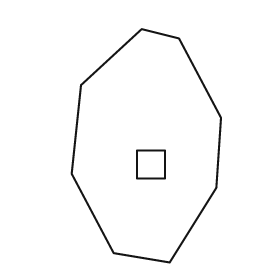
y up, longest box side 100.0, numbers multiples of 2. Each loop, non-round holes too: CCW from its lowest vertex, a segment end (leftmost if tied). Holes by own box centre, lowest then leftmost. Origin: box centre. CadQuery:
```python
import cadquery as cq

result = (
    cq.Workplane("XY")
    .moveTo(10.0, -50.0)
    .lineTo(30.0, -18.0)
    .lineTo(32.0, 12.0)
    .lineTo(14.0, 46.0)
    .lineTo(-2.0, 50.0)
    .lineTo(-28.0, 26.0)
    .lineTo(-32.0, -12.0)
    .lineTo(-14.0, -46.0)
    .close()
    .moveTo(-4.0, -14.0)
    .lineTo(8.0, -14.0)
    .lineTo(8.0, -2.0)
    .lineTo(-4.0, -2.0)
    .close()
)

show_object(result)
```